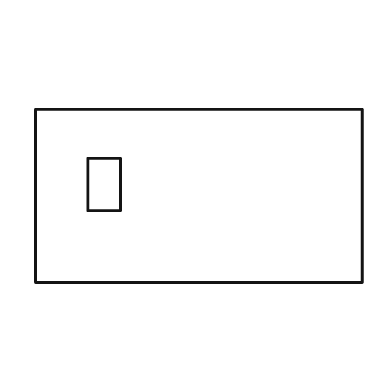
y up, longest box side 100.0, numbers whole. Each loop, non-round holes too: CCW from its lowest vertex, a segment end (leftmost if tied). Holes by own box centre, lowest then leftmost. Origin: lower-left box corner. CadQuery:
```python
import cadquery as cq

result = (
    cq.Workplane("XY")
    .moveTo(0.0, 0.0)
    .lineTo(100.0, 0.0)
    .lineTo(100.0, 53.0)
    .lineTo(0.0, 53.0)
    .close()
    .moveTo(16.0, 22.0)
    .lineTo(26.0, 22.0)
    .lineTo(26.0, 38.0)
    .lineTo(16.0, 38.0)
    .close()
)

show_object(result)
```